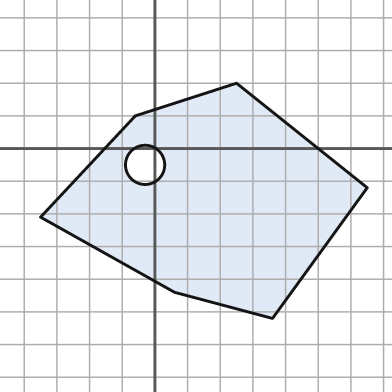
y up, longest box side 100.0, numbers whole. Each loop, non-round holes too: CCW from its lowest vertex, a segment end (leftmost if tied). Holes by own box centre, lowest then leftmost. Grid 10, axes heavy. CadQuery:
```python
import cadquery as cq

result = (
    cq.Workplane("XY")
    .moveTo(36.0, -52.0)
    .lineTo(65.0, -12.0)
    .lineTo(25.0, 20.0)
    .lineTo(-6.0, 10.0)
    .lineTo(-35.0, -21.0)
    .lineTo(6.0, -44.0)
    .close()
    .moveTo(-3.0, -5.0)
    .circle(6.0)
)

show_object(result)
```